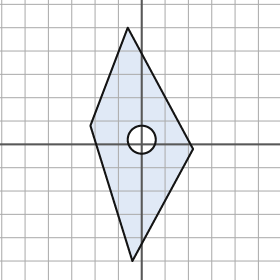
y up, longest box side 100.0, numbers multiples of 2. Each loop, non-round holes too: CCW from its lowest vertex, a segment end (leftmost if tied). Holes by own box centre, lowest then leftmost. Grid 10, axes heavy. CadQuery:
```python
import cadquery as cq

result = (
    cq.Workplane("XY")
    .moveTo(-4.0, -50.0)
    .lineTo(22.0, -2.0)
    .lineTo(-6.0, 50.0)
    .lineTo(-22.0, 8.0)
    .close()
    .moveTo(0.0, 2.0)
    .circle(6.0)
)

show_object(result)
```